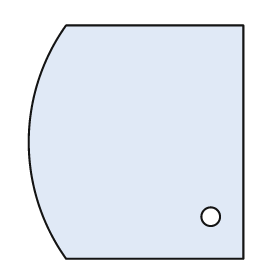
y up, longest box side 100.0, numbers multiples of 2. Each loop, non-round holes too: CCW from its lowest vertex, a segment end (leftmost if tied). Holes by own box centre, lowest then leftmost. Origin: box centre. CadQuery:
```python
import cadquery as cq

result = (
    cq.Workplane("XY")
    .moveTo(-30.0, -50.0)
    .lineTo(46.0, -50.0)
    .lineTo(46.0, 50.0)
    .lineTo(-30.0, 50.0)
    .threePointArc((-46.0, 0.0), (-30.0, -50.0))
    .close()
    .moveTo(32.0, -32.0)
    .circle(4.0)
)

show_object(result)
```